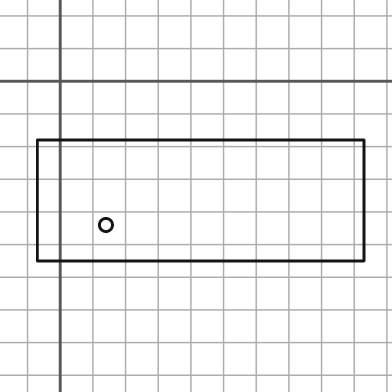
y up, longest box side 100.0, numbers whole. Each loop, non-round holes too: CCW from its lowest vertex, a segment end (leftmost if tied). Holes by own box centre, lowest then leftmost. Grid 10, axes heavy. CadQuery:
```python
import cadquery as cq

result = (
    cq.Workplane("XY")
    .moveTo(-7.0, -55.0)
    .lineTo(93.0, -55.0)
    .lineTo(93.0, -18.0)
    .lineTo(-7.0, -18.0)
    .close()
    .moveTo(14.0, -44.0)
    .circle(2.0)
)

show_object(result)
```